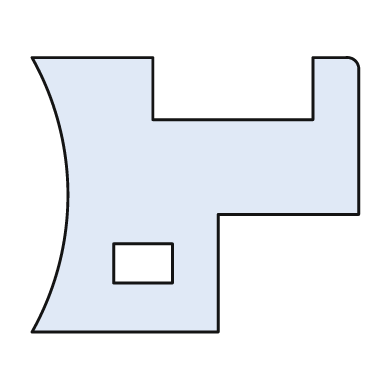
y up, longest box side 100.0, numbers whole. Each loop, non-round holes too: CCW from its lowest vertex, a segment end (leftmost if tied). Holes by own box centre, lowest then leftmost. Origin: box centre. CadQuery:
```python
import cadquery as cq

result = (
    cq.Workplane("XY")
    .moveTo(-50.0, -42.0)
    .lineTo(7.0, -42.0)
    .lineTo(7.0, -6.0)
    .lineTo(50.0, -6.0)
    .lineTo(50.0, 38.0)
    .threePointArc((49.0, 41.0), (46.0, 42.0))
    .lineTo(36.0, 42.0)
    .lineTo(36.0, 23.0)
    .lineTo(-13.0, 23.0)
    .lineTo(-13.0, 42.0)
    .lineTo(-50.0, 42.0)
    .threePointArc((-39.0, 0.0), (-50.0, -42.0))
    .close()
    .moveTo(-25.0, -27.0)
    .lineTo(-7.0, -27.0)
    .lineTo(-7.0, -15.0)
    .lineTo(-25.0, -15.0)
    .close()
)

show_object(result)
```